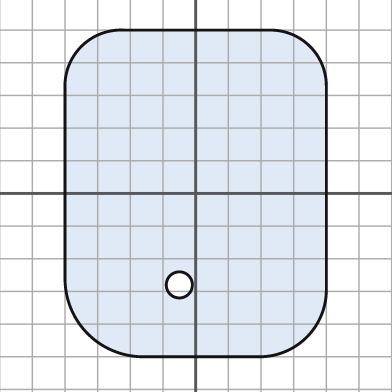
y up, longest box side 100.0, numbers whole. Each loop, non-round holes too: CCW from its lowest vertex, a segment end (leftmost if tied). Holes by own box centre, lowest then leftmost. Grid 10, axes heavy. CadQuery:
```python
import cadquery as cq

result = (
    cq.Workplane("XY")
    .moveTo(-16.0, -50.0)
    .lineTo(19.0, -50.0)
    .threePointArc((34.0, -44.0), (40.0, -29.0))
    .lineTo(40.0, 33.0)
    .threePointArc((35.0, 45.0), (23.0, 50.0))
    .lineTo(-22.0, 50.0)
    .threePointArc((-35.0, 45.0), (-40.0, 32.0))
    .lineTo(-40.0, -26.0)
    .threePointArc((-33.0, -43.0), (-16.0, -50.0))
    .close()
    .moveTo(-5.0, -28.0)
    .circle(4.0)
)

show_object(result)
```